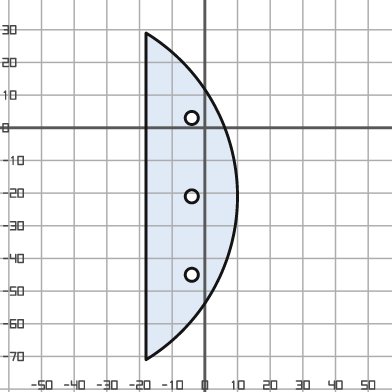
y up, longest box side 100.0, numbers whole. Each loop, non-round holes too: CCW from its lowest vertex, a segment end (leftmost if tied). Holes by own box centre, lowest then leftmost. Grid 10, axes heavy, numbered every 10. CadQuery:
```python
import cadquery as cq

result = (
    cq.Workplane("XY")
    .moveTo(-18.0, -71.0)
    .threePointArc((10.0, -21.0), (-18.0, 29.0))
    .close()
    .moveTo(-4.0, -45.0)
    .circle(2.0)
    .moveTo(-4.0, -21.0)
    .circle(2.0)
    .moveTo(-4.0, 3.0)
    .circle(2.0)
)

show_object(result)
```